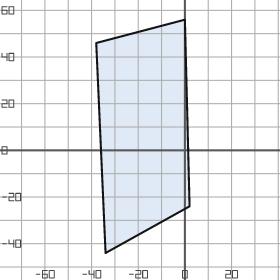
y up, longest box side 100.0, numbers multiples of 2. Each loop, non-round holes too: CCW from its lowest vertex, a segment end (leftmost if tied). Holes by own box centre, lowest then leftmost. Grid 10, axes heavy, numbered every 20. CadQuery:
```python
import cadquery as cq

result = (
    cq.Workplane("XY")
    .moveTo(-34.0, -44.0)
    .lineTo(2.0, -24.0)
    .lineTo(0.0, 56.0)
    .lineTo(-38.0, 46.0)
    .close()
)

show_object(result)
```